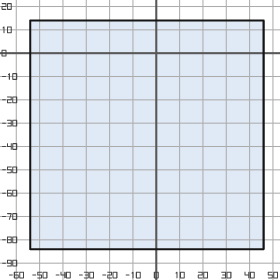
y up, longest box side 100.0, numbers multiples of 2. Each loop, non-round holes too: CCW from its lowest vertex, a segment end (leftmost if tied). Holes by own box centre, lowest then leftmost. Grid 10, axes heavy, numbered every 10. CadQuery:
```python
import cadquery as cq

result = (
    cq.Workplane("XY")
    .moveTo(-54.0, -84.0)
    .lineTo(46.0, -84.0)
    .lineTo(46.0, 14.0)
    .lineTo(-54.0, 14.0)
    .close()
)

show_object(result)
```